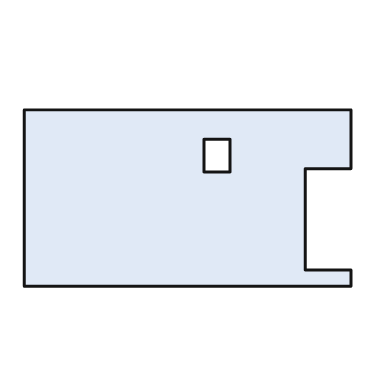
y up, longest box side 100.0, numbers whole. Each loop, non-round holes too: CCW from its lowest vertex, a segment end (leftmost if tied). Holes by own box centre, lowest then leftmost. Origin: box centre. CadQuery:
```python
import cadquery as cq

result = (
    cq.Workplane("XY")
    .moveTo(-50.0, -27.0)
    .lineTo(50.0, -27.0)
    .lineTo(50.0, -22.0)
    .lineTo(36.0, -22.0)
    .lineTo(36.0, 9.0)
    .lineTo(50.0, 9.0)
    .lineTo(50.0, 27.0)
    .lineTo(-50.0, 27.0)
    .close()
    .moveTo(5.0, 8.0)
    .lineTo(13.0, 8.0)
    .lineTo(13.0, 18.0)
    .lineTo(5.0, 18.0)
    .close()
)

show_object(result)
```